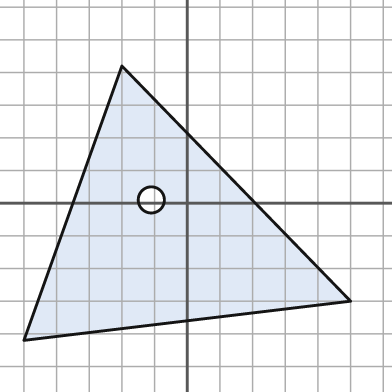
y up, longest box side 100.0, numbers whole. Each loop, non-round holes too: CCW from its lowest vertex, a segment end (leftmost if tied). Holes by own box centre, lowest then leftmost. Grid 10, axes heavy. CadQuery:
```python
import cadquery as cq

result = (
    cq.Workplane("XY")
    .moveTo(-50.0, -42.0)
    .lineTo(50.0, -30.0)
    .lineTo(-20.0, 42.0)
    .close()
    .moveTo(-11.0, 1.0)
    .circle(4.0)
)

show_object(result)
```